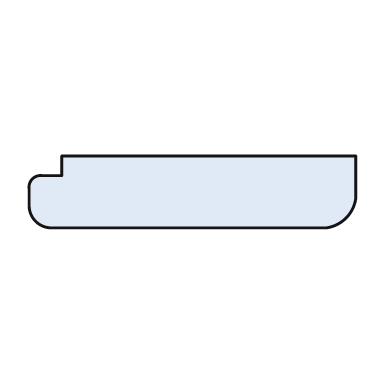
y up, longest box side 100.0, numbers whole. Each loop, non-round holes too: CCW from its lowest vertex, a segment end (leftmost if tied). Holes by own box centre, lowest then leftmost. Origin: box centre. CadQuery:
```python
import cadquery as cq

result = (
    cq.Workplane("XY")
    .moveTo(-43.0, -11.0)
    .lineTo(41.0, -11.0)
    .threePointArc((47.0, -8.0), (50.0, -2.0))
    .lineTo(50.0, 11.0)
    .lineTo(-40.0, 11.0)
    .lineTo(-40.0, 5.0)
    .lineTo(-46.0, 5.0)
    .threePointArc((-49.0, 4.0), (-50.0, 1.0))
    .lineTo(-50.0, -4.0)
    .threePointArc((-48.0, -9.0), (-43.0, -11.0))
    .close()
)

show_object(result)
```